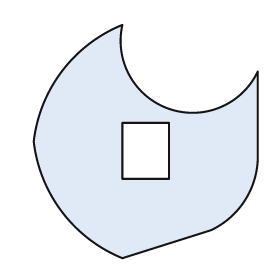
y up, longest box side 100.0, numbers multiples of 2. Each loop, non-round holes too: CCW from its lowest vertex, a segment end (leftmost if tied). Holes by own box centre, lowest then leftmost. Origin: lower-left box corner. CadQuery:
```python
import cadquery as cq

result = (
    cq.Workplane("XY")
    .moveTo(38.0, 0.0)
    .lineTo(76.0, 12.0)
    .threePointArc((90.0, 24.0), (96.0, 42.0))
    .lineTo(96.0, 80.0)
    .threePointArc((58.0, 64.0), (38.0, 100.0))
    .threePointArc((12.0, 80.0), (0.0, 50.0))
    .threePointArc((12.0, 20.0), (38.0, 0.0))
    .close()
    .moveTo(38.0, 34.0)
    .lineTo(58.0, 34.0)
    .lineTo(58.0, 58.0)
    .lineTo(38.0, 58.0)
    .close()
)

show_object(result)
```